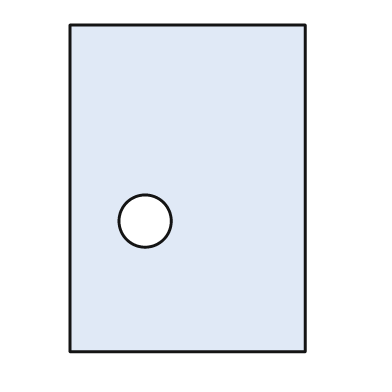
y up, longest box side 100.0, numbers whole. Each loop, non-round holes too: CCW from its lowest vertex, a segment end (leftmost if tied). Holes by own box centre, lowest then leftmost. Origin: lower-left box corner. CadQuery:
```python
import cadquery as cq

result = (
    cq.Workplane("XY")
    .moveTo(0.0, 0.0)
    .lineTo(72.0, 0.0)
    .lineTo(72.0, 100.0)
    .lineTo(0.0, 100.0)
    .close()
    .moveTo(23.0, 40.0)
    .circle(8.0)
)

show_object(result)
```